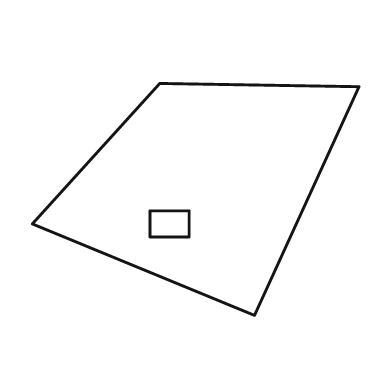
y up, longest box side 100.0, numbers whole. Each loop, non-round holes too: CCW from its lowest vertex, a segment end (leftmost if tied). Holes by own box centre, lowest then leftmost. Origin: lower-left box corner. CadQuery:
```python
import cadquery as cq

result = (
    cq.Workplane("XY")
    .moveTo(68.0, 0.0)
    .lineTo(100.0, 70.0)
    .lineTo(39.0, 71.0)
    .lineTo(0.0, 28.0)
    .close()
    .moveTo(36.0, 24.0)
    .lineTo(48.0, 24.0)
    .lineTo(48.0, 32.0)
    .lineTo(36.0, 32.0)
    .close()
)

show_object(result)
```